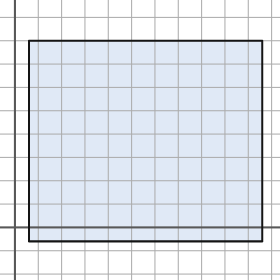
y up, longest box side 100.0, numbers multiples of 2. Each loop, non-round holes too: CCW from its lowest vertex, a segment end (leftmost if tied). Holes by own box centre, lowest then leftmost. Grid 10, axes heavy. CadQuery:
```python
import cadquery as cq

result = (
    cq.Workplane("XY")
    .moveTo(6.0, -6.0)
    .lineTo(106.0, -6.0)
    .lineTo(106.0, 80.0)
    .lineTo(6.0, 80.0)
    .close()
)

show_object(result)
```